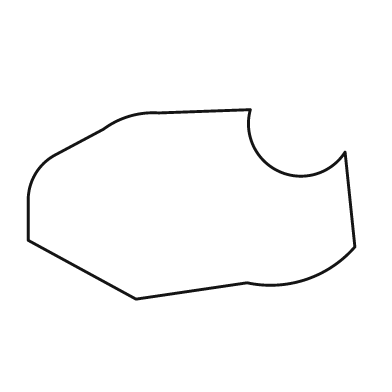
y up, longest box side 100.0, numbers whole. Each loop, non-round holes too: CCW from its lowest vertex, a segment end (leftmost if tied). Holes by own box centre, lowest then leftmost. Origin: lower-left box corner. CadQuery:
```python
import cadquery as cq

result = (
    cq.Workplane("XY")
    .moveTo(33.0, 0.0)
    .lineTo(67.0, 5.0)
    .threePointArc((85.0, 6.0), (100.0, 16.0))
    .lineTo(97.0, 45.0)
    .threePointArc((77.0, 39.0), (68.0, 58.0))
    .lineTo(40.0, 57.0)
    .threePointArc((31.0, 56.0), (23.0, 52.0))
    .lineTo(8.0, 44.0)
    .threePointArc((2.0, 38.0), (0.0, 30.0))
    .lineTo(0.0, 18.0)
    .close()
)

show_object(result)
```